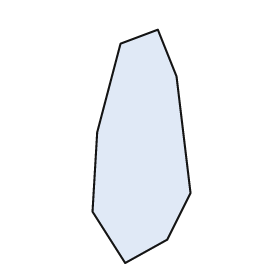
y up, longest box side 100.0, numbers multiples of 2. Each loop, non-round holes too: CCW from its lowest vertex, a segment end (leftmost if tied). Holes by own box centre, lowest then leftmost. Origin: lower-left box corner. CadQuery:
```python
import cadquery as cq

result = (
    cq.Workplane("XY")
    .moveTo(14.0, 0.0)
    .lineTo(32.0, 10.0)
    .lineTo(42.0, 30.0)
    .lineTo(36.0, 80.0)
    .lineTo(28.0, 100.0)
    .lineTo(12.0, 94.0)
    .lineTo(2.0, 56.0)
    .lineTo(0.0, 22.0)
    .close()
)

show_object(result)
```